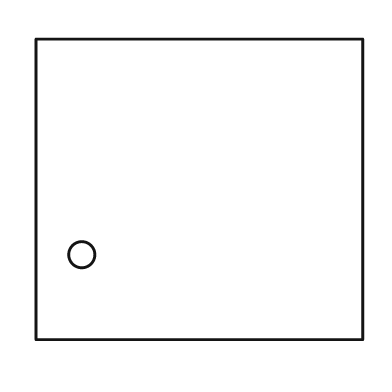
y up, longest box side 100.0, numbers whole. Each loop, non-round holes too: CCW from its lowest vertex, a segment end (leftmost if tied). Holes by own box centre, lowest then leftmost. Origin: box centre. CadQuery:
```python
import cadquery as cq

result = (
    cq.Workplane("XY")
    .moveTo(-50.0, -46.0)
    .lineTo(50.0, -46.0)
    .lineTo(50.0, 46.0)
    .lineTo(-50.0, 46.0)
    .close()
    .moveTo(-36.0, -20.0)
    .circle(4.0)
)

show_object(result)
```